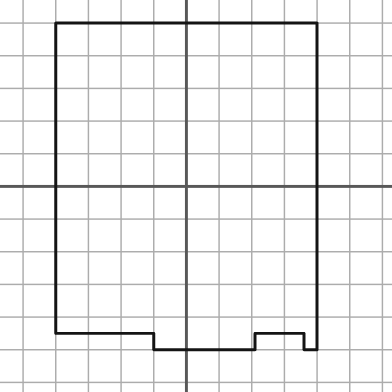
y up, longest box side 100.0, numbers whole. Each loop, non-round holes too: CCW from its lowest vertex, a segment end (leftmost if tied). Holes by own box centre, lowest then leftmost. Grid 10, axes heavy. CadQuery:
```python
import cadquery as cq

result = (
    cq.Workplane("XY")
    .moveTo(-10.0, -50.0)
    .lineTo(21.0, -50.0)
    .lineTo(21.0, -45.0)
    .lineTo(36.0, -45.0)
    .lineTo(36.0, -50.0)
    .lineTo(40.0, -50.0)
    .lineTo(40.0, 50.0)
    .lineTo(-40.0, 50.0)
    .lineTo(-40.0, -45.0)
    .lineTo(-10.0, -45.0)
    .close()
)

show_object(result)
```